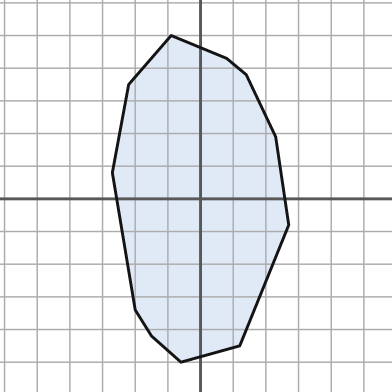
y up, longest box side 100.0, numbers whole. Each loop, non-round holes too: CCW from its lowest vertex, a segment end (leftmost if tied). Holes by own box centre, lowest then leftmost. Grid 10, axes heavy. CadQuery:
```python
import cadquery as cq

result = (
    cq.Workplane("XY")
    .moveTo(-6.0, -50.0)
    .lineTo(12.0, -45.0)
    .lineTo(27.0, -8.0)
    .lineTo(23.0, 19.0)
    .lineTo(14.0, 38.0)
    .lineTo(8.0, 43.0)
    .lineTo(-9.0, 50.0)
    .lineTo(-22.0, 35.0)
    .lineTo(-27.0, 8.0)
    .lineTo(-20.0, -34.0)
    .lineTo(-15.0, -42.0)
    .close()
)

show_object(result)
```